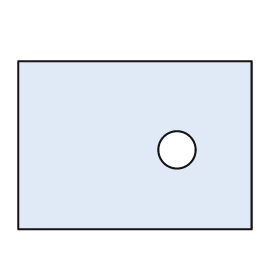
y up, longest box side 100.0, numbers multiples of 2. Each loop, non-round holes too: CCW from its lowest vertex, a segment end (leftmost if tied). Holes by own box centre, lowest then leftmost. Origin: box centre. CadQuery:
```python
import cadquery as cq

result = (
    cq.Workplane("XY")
    .moveTo(-50.0, -36.0)
    .lineTo(50.0, -36.0)
    .lineTo(50.0, 36.0)
    .lineTo(-50.0, 36.0)
    .close()
    .moveTo(18.0, -2.0)
    .circle(8.0)
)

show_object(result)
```